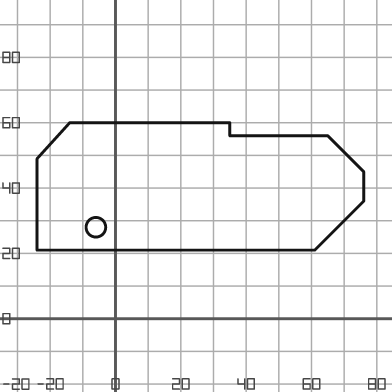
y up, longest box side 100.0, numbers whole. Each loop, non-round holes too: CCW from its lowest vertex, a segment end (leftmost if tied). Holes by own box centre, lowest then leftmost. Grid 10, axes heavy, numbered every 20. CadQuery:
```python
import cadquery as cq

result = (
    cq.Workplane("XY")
    .moveTo(-24.0, 21.0)
    .lineTo(61.0, 21.0)
    .lineTo(76.0, 36.0)
    .lineTo(76.0, 45.0)
    .lineTo(65.0, 56.0)
    .lineTo(35.0, 56.0)
    .lineTo(35.0, 60.0)
    .lineTo(-14.0, 60.0)
    .lineTo(-24.0, 49.0)
    .close()
    .moveTo(-6.0, 28.0)
    .circle(3.0)
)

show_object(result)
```